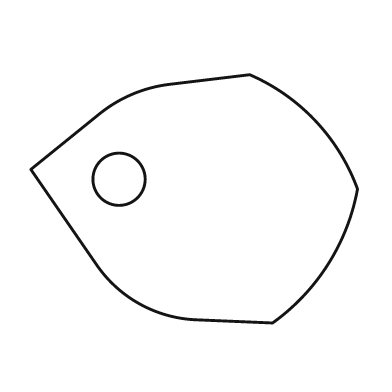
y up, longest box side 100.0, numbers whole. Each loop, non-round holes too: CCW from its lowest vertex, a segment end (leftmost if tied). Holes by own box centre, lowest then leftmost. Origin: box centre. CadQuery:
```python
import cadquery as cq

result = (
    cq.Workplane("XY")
    .moveTo(24.0, -38.0)
    .threePointArc((41.0, -20.0), (50.0, 3.0))
    .threePointArc((37.0, 24.0), (17.0, 38.0))
    .lineTo(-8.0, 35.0)
    .threePointArc((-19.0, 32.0), (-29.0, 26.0))
    .lineTo(-50.0, 9.0)
    .lineTo(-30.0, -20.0)
    .threePointArc((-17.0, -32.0), (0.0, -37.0))
    .close()
    .moveTo(-23.0, 6.0)
    .circle(8.0)
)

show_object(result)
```